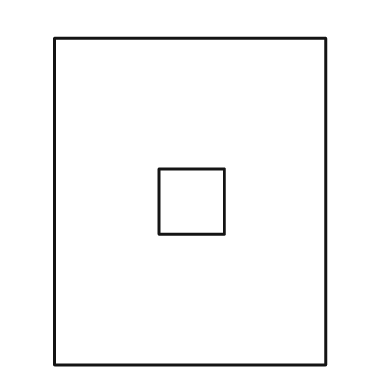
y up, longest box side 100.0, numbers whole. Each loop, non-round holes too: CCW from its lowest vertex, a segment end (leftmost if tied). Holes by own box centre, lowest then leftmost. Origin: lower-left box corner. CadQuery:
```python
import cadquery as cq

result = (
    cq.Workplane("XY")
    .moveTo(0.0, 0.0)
    .lineTo(83.0, 0.0)
    .lineTo(83.0, 100.0)
    .lineTo(0.0, 100.0)
    .close()
    .moveTo(32.0, 40.0)
    .lineTo(52.0, 40.0)
    .lineTo(52.0, 60.0)
    .lineTo(32.0, 60.0)
    .close()
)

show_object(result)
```